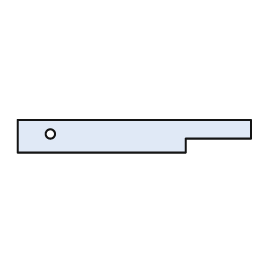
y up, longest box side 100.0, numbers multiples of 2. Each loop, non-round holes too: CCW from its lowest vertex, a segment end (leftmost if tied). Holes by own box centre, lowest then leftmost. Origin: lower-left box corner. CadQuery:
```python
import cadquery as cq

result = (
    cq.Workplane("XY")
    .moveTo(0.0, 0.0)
    .lineTo(72.0, 0.0)
    .lineTo(72.0, 6.0)
    .lineTo(100.0, 6.0)
    .lineTo(100.0, 14.0)
    .lineTo(0.0, 14.0)
    .close()
    .moveTo(14.0, 8.0)
    .circle(2.0)
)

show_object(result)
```